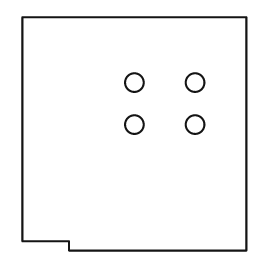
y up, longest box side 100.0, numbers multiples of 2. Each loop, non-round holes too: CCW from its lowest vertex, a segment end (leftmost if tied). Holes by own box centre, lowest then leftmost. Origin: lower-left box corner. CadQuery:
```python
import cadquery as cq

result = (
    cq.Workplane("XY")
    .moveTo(20.0, 0.0)
    .lineTo(96.0, 0.0)
    .lineTo(96.0, 100.0)
    .lineTo(0.0, 100.0)
    .lineTo(0.0, 4.0)
    .lineTo(20.0, 4.0)
    .close()
    .moveTo(48.0, 54.0)
    .circle(4.0)
    .moveTo(74.0, 54.0)
    .circle(4.0)
    .moveTo(48.0, 72.0)
    .circle(4.0)
    .moveTo(74.0, 72.0)
    .circle(4.0)
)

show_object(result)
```